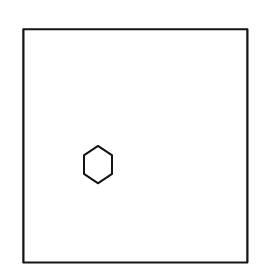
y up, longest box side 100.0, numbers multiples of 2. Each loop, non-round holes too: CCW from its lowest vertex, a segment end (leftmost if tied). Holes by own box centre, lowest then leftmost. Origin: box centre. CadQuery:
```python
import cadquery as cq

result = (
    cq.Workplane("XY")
    .moveTo(-48.0, -50.0)
    .lineTo(48.0, -50.0)
    .lineTo(48.0, 50.0)
    .lineTo(-48.0, 50.0)
    .close()
    .moveTo(-16.0, -16.0)
    .lineTo(-10.0, -12.0)
    .lineTo(-10.0, -4.0)
    .lineTo(-16.0, 0.0)
    .lineTo(-22.0, -4.0)
    .lineTo(-22.0, -12.0)
    .close()
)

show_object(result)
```